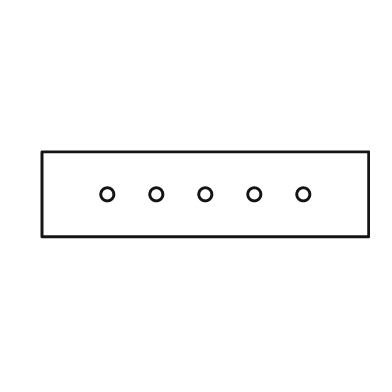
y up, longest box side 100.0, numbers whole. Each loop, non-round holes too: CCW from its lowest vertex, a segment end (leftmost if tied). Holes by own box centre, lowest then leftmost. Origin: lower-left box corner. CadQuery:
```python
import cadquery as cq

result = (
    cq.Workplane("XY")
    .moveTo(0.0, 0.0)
    .lineTo(100.0, 0.0)
    .lineTo(100.0, 26.0)
    .lineTo(0.0, 26.0)
    .close()
    .moveTo(20.0, 13.0)
    .circle(2.0)
    .moveTo(35.0, 13.0)
    .circle(2.0)
    .moveTo(50.0, 13.0)
    .circle(2.0)
    .moveTo(65.0, 13.0)
    .circle(2.0)
    .moveTo(80.0, 13.0)
    .circle(2.0)
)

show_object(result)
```